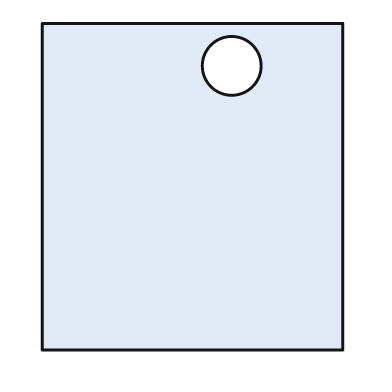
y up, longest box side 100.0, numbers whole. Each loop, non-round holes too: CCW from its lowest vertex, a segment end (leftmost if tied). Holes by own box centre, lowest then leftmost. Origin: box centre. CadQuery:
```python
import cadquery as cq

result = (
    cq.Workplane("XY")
    .moveTo(-46.0, -50.0)
    .lineTo(46.0, -50.0)
    .lineTo(46.0, 50.0)
    .lineTo(-46.0, 50.0)
    .close()
    .moveTo(12.0, 37.0)
    .circle(9.0)
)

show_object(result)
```